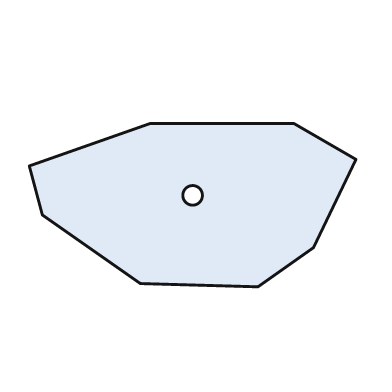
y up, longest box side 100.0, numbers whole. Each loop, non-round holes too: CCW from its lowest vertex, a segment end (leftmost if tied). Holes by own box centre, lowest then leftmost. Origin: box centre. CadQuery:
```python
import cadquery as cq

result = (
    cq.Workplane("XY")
    .moveTo(20.0, -25.0)
    .lineTo(37.0, -13.0)
    .lineTo(50.0, 14.0)
    .lineTo(31.0, 25.0)
    .lineTo(-13.0, 25.0)
    .lineTo(-50.0, 12.0)
    .lineTo(-46.0, -3.0)
    .lineTo(-16.0, -24.0)
    .close()
    .moveTo(0.0, 3.0)
    .circle(3.0)
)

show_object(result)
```